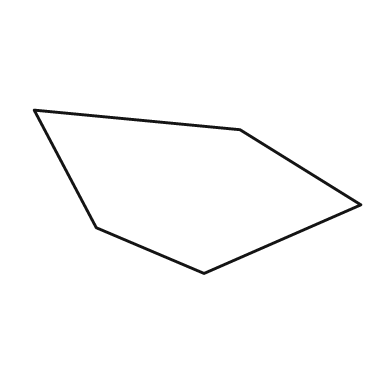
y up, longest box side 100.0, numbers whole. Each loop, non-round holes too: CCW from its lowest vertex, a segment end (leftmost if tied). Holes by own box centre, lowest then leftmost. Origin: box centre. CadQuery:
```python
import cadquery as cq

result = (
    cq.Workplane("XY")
    .moveTo(2.0, -25.0)
    .lineTo(50.0, -4.0)
    .lineTo(13.0, 19.0)
    .lineTo(-50.0, 25.0)
    .lineTo(-31.0, -11.0)
    .close()
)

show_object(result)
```